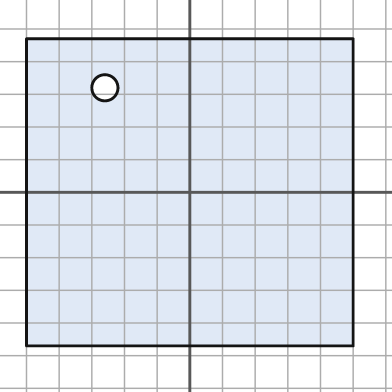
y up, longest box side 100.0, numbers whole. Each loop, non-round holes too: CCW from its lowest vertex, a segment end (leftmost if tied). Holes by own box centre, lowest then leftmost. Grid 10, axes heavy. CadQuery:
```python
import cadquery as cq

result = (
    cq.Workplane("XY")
    .moveTo(-50.0, -47.0)
    .lineTo(50.0, -47.0)
    .lineTo(50.0, 47.0)
    .lineTo(-50.0, 47.0)
    .close()
    .moveTo(-26.0, 32.0)
    .circle(4.0)
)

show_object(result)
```